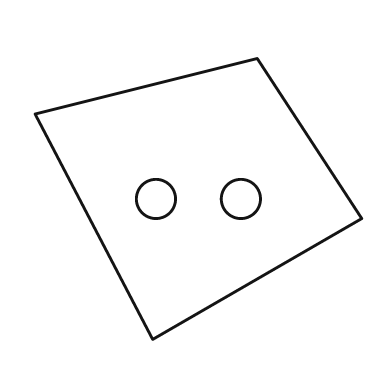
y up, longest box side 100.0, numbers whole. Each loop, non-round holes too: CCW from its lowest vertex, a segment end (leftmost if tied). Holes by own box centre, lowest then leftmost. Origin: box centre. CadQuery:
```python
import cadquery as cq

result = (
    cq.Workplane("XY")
    .moveTo(-14.0, -43.0)
    .lineTo(50.0, -6.0)
    .lineTo(18.0, 43.0)
    .lineTo(-50.0, 26.0)
    .close()
    .moveTo(-13.0, 0.0)
    .circle(6.0)
    .moveTo(13.0, 0.0)
    .circle(6.0)
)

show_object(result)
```